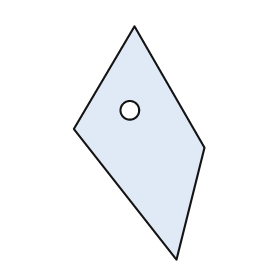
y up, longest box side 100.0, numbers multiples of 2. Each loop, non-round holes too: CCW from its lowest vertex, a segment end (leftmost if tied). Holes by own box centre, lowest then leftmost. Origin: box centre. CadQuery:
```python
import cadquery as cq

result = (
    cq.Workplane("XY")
    .moveTo(16.0, -50.0)
    .lineTo(28.0, -2.0)
    .lineTo(-2.0, 50.0)
    .lineTo(-28.0, 6.0)
    .close()
    .moveTo(-4.0, 14.0)
    .circle(4.0)
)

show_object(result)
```